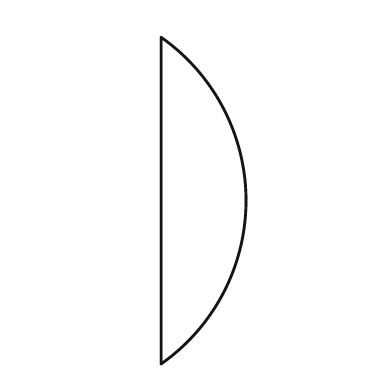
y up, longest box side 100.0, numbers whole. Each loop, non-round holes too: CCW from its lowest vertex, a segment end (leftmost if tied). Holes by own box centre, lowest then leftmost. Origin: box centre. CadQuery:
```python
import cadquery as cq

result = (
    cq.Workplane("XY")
    .moveTo(-13.0, -50.0)
    .threePointArc((13.0, 0.0), (-13.0, 50.0))
    .close()
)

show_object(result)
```